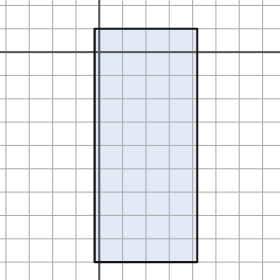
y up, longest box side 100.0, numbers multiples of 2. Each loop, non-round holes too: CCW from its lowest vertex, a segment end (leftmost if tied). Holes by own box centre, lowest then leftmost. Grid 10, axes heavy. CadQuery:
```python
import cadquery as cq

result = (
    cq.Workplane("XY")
    .moveTo(-2.0, -90.0)
    .lineTo(42.0, -90.0)
    .lineTo(42.0, 10.0)
    .lineTo(-2.0, 10.0)
    .close()
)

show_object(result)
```